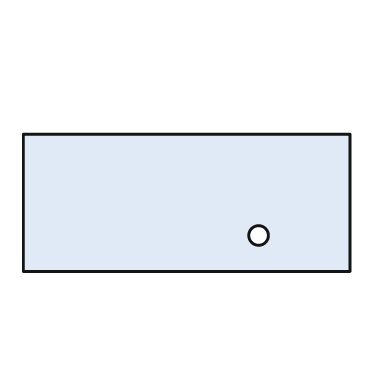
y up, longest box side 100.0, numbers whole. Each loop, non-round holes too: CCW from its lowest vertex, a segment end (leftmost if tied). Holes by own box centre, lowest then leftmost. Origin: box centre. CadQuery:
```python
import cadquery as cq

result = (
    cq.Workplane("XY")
    .moveTo(-50.0, -21.0)
    .lineTo(50.0, -21.0)
    .lineTo(50.0, 21.0)
    .lineTo(-50.0, 21.0)
    .close()
    .moveTo(22.0, -10.0)
    .circle(3.0)
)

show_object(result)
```